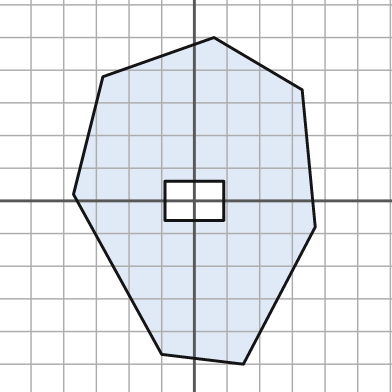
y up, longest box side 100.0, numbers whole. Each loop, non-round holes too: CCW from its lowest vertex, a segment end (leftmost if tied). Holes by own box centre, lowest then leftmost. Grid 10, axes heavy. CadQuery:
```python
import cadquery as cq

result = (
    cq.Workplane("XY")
    .moveTo(15.0, -50.0)
    .lineTo(37.0, -8.0)
    .lineTo(33.0, 34.0)
    .lineTo(6.0, 50.0)
    .lineTo(-28.0, 38.0)
    .lineTo(-37.0, 2.0)
    .lineTo(-10.0, -47.0)
    .close()
    .moveTo(-9.0, -6.0)
    .lineTo(9.0, -6.0)
    .lineTo(9.0, 6.0)
    .lineTo(-9.0, 6.0)
    .close()
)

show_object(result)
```